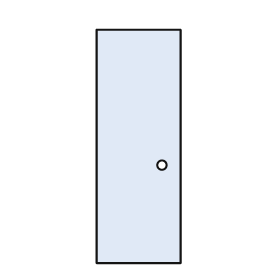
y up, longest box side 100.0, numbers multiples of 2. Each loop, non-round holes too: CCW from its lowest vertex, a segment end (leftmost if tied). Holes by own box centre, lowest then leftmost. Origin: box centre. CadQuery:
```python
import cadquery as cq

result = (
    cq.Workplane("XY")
    .moveTo(-18.0, -50.0)
    .lineTo(18.0, -50.0)
    .lineTo(18.0, 50.0)
    .lineTo(-18.0, 50.0)
    .close()
    .moveTo(10.0, -8.0)
    .circle(2.0)
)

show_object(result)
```